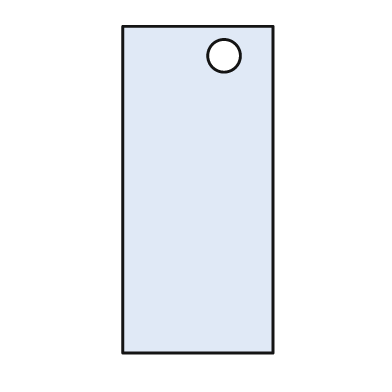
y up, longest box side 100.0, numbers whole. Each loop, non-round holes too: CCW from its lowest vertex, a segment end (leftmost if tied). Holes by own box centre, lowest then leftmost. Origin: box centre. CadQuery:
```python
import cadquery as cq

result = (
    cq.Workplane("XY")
    .moveTo(-23.0, -50.0)
    .lineTo(23.0, -50.0)
    .lineTo(23.0, 50.0)
    .lineTo(-23.0, 50.0)
    .close()
    .moveTo(8.0, 41.0)
    .circle(5.0)
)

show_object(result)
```